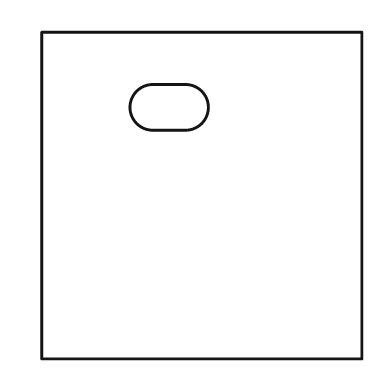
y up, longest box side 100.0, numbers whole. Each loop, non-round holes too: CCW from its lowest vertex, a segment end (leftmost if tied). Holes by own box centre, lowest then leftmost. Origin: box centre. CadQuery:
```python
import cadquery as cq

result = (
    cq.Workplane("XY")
    .moveTo(-49.0, -50.0)
    .lineTo(49.0, -50.0)
    .lineTo(49.0, 50.0)
    .lineTo(-49.0, 50.0)
    .close()
    .moveTo(-15.0, 20.0)
    .lineTo(-5.0, 20.0)
    .threePointArc((2.0, 27.0), (-5.0, 34.0))
    .lineTo(-15.0, 34.0)
    .threePointArc((-22.0, 27.0), (-15.0, 20.0))
    .close()
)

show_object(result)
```